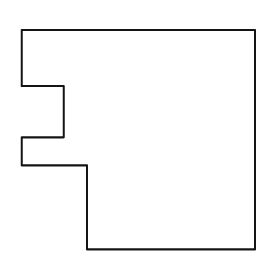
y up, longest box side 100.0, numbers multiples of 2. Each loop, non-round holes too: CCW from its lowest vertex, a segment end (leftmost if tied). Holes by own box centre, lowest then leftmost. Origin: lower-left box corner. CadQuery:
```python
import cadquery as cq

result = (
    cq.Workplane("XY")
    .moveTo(28.0, 0.0)
    .lineTo(100.0, 0.0)
    .lineTo(100.0, 94.0)
    .lineTo(0.0, 94.0)
    .lineTo(0.0, 70.0)
    .lineTo(18.0, 70.0)
    .lineTo(18.0, 48.0)
    .lineTo(0.0, 48.0)
    .lineTo(0.0, 36.0)
    .lineTo(28.0, 36.0)
    .close()
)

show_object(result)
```